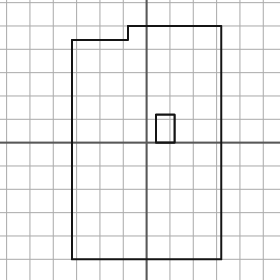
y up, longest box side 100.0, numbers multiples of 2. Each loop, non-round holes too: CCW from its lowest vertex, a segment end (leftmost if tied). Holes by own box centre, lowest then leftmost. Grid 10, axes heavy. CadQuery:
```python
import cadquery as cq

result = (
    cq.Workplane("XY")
    .moveTo(-32.0, -50.0)
    .lineTo(32.0, -50.0)
    .lineTo(32.0, 50.0)
    .lineTo(-8.0, 50.0)
    .lineTo(-8.0, 44.0)
    .lineTo(-32.0, 44.0)
    .close()
    .moveTo(4.0, 0.0)
    .lineTo(12.0, 0.0)
    .lineTo(12.0, 12.0)
    .lineTo(4.0, 12.0)
    .close()
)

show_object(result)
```